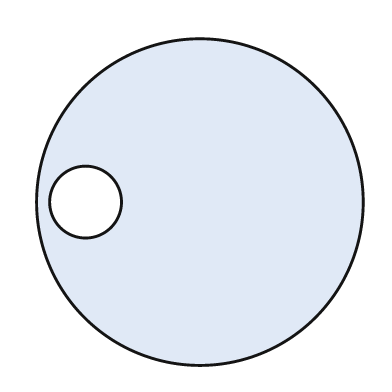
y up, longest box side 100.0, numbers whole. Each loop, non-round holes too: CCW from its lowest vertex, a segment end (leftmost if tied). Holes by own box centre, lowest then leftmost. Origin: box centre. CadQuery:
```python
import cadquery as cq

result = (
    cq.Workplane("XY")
    .moveTo(0.0, 0.0)
    .circle(50.0)
    .moveTo(-35.0, 0.0)
    .circle(11.0)
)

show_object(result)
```